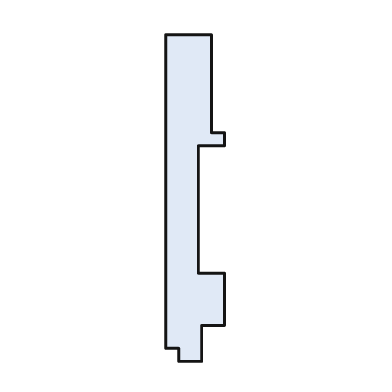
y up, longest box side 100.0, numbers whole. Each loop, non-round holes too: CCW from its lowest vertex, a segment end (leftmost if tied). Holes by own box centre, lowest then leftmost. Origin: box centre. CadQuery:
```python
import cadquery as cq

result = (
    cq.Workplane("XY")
    .moveTo(-5.0, -50.0)
    .lineTo(2.0, -50.0)
    .lineTo(2.0, -39.0)
    .lineTo(9.0, -39.0)
    .lineTo(9.0, -23.0)
    .lineTo(1.0, -23.0)
    .lineTo(1.0, 16.0)
    .lineTo(9.0, 16.0)
    .lineTo(9.0, 20.0)
    .lineTo(5.0, 20.0)
    .lineTo(5.0, 50.0)
    .lineTo(-9.0, 50.0)
    .lineTo(-9.0, -46.0)
    .lineTo(-5.0, -46.0)
    .close()
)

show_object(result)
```